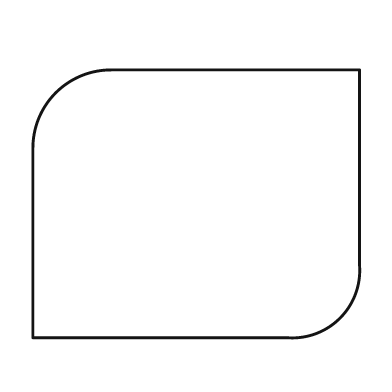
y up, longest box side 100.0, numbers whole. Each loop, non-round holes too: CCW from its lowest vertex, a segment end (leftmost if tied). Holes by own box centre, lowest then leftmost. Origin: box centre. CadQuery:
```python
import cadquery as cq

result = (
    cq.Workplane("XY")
    .moveTo(-50.0, -41.0)
    .lineTo(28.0, -41.0)
    .threePointArc((44.0, -35.0), (50.0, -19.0))
    .lineTo(50.0, 41.0)
    .lineTo(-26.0, 41.0)
    .threePointArc((-43.0, 34.0), (-50.0, 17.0))
    .close()
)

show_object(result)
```